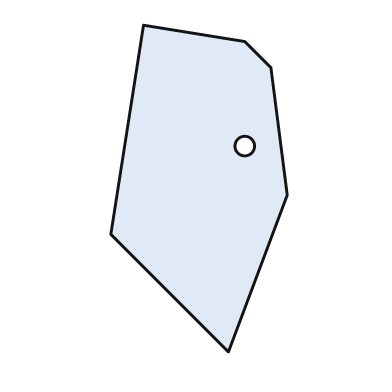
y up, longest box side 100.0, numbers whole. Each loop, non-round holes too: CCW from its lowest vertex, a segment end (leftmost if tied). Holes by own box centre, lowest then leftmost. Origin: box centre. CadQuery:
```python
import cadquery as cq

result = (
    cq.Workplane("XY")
    .moveTo(9.0, -50.0)
    .lineTo(27.0, -2.0)
    .lineTo(22.0, 37.0)
    .lineTo(14.0, 45.0)
    .lineTo(-17.0, 50.0)
    .lineTo(-27.0, -14.0)
    .close()
    .moveTo(14.0, 13.0)
    .circle(3.0)
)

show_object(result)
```